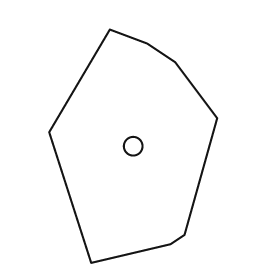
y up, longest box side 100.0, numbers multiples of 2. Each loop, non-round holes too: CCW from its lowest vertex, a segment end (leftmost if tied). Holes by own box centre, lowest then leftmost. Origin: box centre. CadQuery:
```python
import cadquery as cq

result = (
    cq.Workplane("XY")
    .moveTo(-18.0, -50.0)
    .lineTo(16.0, -42.0)
    .lineTo(22.0, -38.0)
    .lineTo(36.0, 12.0)
    .lineTo(18.0, 36.0)
    .lineTo(6.0, 44.0)
    .lineTo(-10.0, 50.0)
    .lineTo(-36.0, 6.0)
    .close()
    .moveTo(0.0, 0.0)
    .circle(4.0)
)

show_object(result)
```